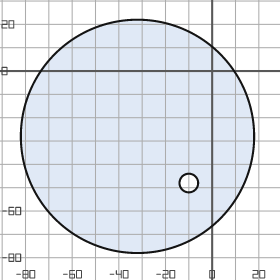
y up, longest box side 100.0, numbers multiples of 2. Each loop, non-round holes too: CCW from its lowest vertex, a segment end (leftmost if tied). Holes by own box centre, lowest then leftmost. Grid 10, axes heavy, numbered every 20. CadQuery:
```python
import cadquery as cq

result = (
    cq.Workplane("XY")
    .moveTo(-32.0, -28.0)
    .circle(50.0)
    .moveTo(-10.0, -48.0)
    .circle(4.0)
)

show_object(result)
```